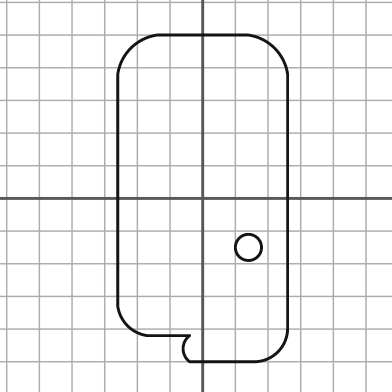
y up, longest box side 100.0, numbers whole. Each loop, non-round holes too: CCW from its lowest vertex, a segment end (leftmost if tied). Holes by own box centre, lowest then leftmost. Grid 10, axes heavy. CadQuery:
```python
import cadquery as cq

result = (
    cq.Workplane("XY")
    .moveTo(-4.0, -50.0)
    .lineTo(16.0, -50.0)
    .threePointArc((23.0, -47.0), (26.0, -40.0))
    .lineTo(26.0, 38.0)
    .threePointArc((22.0, 46.0), (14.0, 50.0))
    .lineTo(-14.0, 50.0)
    .threePointArc((-22.0, 46.0), (-26.0, 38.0))
    .lineTo(-26.0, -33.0)
    .threePointArc((-23.0, -39.0), (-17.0, -42.0))
    .lineTo(-4.0, -42.0)
    .threePointArc((-6.0, -46.0), (-4.0, -50.0))
    .close()
    .moveTo(14.0, -15.0)
    .circle(4.0)
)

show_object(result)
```